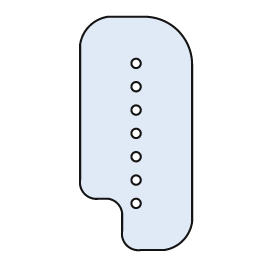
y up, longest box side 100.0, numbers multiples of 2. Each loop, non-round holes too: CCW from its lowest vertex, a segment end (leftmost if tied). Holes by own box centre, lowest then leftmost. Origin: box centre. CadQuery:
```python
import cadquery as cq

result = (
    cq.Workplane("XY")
    .moveTo(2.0, -50.0)
    .lineTo(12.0, -50.0)
    .threePointArc((20.0, -46.0), (24.0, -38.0))
    .lineTo(24.0, 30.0)
    .threePointArc((18.0, 44.0), (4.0, 50.0))
    .lineTo(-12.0, 50.0)
    .threePointArc((-20.0, 46.0), (-24.0, 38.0))
    .lineTo(-24.0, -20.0)
    .threePointArc((-22.0, -26.0), (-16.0, -28.0))
    .lineTo(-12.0, -28.0)
    .threePointArc((-8.0, -30.0), (-6.0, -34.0))
    .lineTo(-6.0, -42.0)
    .threePointArc((-4.0, -48.0), (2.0, -50.0))
    .close()
    .moveTo(0.0, -30.0)
    .circle(2.0)
    .moveTo(0.0, -20.0)
    .circle(2.0)
    .moveTo(0.0, -10.0)
    .circle(2.0)
    .moveTo(0.0, 0.0)
    .circle(2.0)
    .moveTo(0.0, 10.0)
    .circle(2.0)
    .moveTo(0.0, 20.0)
    .circle(2.0)
    .moveTo(0.0, 30.0)
    .circle(2.0)
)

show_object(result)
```